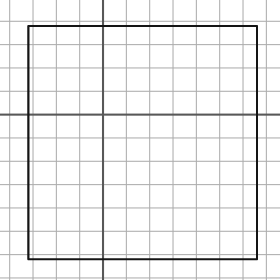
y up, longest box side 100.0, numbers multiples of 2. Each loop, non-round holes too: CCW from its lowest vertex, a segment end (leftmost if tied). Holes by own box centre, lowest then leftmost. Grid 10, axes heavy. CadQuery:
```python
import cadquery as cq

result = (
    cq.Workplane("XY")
    .moveTo(-32.0, -62.0)
    .lineTo(66.0, -62.0)
    .lineTo(66.0, 38.0)
    .lineTo(-32.0, 38.0)
    .close()
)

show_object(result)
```